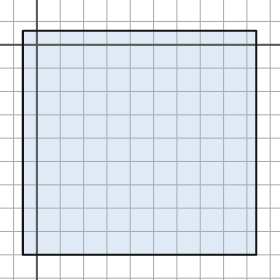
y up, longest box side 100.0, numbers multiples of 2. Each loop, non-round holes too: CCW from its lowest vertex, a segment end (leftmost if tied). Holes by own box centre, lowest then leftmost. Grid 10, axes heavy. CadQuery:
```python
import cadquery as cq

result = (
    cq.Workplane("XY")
    .moveTo(-6.0, -90.0)
    .lineTo(94.0, -90.0)
    .lineTo(94.0, 6.0)
    .lineTo(-6.0, 6.0)
    .close()
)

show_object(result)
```